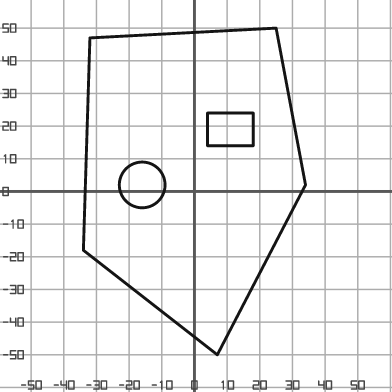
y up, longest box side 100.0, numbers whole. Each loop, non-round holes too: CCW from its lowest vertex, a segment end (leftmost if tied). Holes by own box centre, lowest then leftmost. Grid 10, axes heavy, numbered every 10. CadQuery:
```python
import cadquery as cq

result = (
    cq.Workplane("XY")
    .moveTo(7.0, -50.0)
    .lineTo(34.0, 2.0)
    .lineTo(25.0, 50.0)
    .lineTo(-32.0, 47.0)
    .lineTo(-34.0, -18.0)
    .close()
    .moveTo(-16.0, 2.0)
    .circle(7.0)
    .moveTo(4.0, 14.0)
    .lineTo(18.0, 14.0)
    .lineTo(18.0, 24.0)
    .lineTo(4.0, 24.0)
    .close()
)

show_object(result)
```